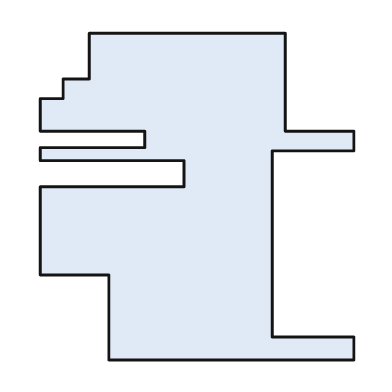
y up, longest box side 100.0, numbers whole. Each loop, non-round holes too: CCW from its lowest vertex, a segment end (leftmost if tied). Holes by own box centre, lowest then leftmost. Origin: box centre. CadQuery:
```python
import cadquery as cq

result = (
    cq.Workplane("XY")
    .moveTo(-27.0, -50.0)
    .lineTo(48.0, -50.0)
    .lineTo(48.0, -43.0)
    .lineTo(23.0, -43.0)
    .lineTo(23.0, 14.0)
    .lineTo(48.0, 14.0)
    .lineTo(48.0, 20.0)
    .lineTo(27.0, 20.0)
    .lineTo(27.0, 50.0)
    .lineTo(-33.0, 50.0)
    .lineTo(-33.0, 36.0)
    .lineTo(-41.0, 36.0)
    .lineTo(-41.0, 30.0)
    .lineTo(-48.0, 30.0)
    .lineTo(-48.0, 20.0)
    .lineTo(-16.0, 20.0)
    .lineTo(-16.0, 15.0)
    .lineTo(-48.0, 15.0)
    .lineTo(-48.0, 11.0)
    .lineTo(-4.0, 11.0)
    .lineTo(-4.0, 3.0)
    .lineTo(-48.0, 3.0)
    .lineTo(-48.0, -24.0)
    .lineTo(-27.0, -24.0)
    .close()
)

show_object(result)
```